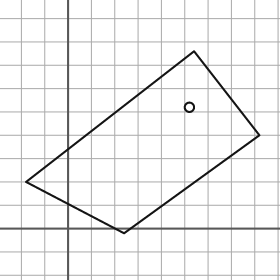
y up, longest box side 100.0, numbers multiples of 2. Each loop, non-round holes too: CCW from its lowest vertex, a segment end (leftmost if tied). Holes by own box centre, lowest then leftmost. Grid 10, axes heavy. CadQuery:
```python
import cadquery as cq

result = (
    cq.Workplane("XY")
    .moveTo(24.0, -2.0)
    .lineTo(82.0, 40.0)
    .lineTo(54.0, 76.0)
    .lineTo(-18.0, 20.0)
    .close()
    .moveTo(52.0, 52.0)
    .circle(2.0)
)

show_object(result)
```